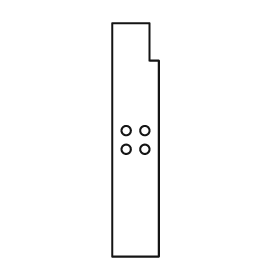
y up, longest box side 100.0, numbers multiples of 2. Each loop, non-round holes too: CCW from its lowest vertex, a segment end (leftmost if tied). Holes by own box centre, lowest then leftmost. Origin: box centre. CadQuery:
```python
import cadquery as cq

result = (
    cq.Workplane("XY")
    .moveTo(-10.0, -50.0)
    .lineTo(10.0, -50.0)
    .lineTo(10.0, 34.0)
    .lineTo(6.0, 34.0)
    .lineTo(6.0, 50.0)
    .lineTo(-10.0, 50.0)
    .close()
    .moveTo(-4.0, -4.0)
    .circle(2.0)
    .moveTo(4.0, -4.0)
    .circle(2.0)
    .moveTo(-4.0, 4.0)
    .circle(2.0)
    .moveTo(4.0, 4.0)
    .circle(2.0)
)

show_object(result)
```